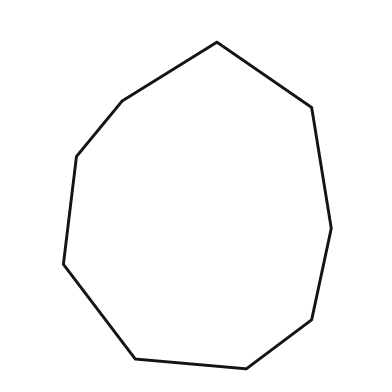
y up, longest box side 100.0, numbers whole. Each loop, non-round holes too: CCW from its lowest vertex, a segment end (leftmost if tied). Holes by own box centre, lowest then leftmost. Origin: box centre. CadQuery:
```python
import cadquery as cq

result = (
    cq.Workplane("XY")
    .moveTo(15.0, -50.0)
    .lineTo(35.0, -35.0)
    .lineTo(41.0, -7.0)
    .lineTo(35.0, 30.0)
    .lineTo(6.0, 50.0)
    .lineTo(-23.0, 32.0)
    .lineTo(-37.0, 15.0)
    .lineTo(-41.0, -18.0)
    .lineTo(-19.0, -47.0)
    .close()
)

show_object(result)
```